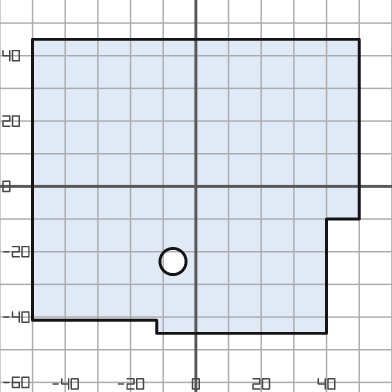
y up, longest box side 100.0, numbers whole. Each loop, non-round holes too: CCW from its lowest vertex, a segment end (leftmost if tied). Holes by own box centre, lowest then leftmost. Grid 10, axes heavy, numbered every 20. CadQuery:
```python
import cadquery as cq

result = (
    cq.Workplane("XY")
    .moveTo(-12.0, -45.0)
    .lineTo(40.0, -45.0)
    .lineTo(40.0, -10.0)
    .lineTo(50.0, -10.0)
    .lineTo(50.0, 45.0)
    .lineTo(-50.0, 45.0)
    .lineTo(-50.0, -41.0)
    .lineTo(-12.0, -41.0)
    .close()
    .moveTo(-7.0, -23.0)
    .circle(4.0)
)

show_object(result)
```